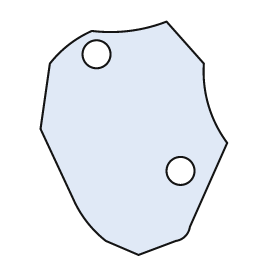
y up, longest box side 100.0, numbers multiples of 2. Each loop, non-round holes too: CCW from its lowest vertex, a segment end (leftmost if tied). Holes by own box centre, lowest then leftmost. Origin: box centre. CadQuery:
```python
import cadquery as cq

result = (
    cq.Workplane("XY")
    .moveTo(2.0, -50.0)
    .lineTo(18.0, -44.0)
    .threePointArc((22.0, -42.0), (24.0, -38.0))
    .lineTo(40.0, -2.0)
    .threePointArc((32.0, 14.0), (30.0, 32.0))
    .lineTo(14.0, 50.0)
    .threePointArc((-2.0, 46.0), (-18.0, 46.0))
    .threePointArc((-28.0, 40.0), (-36.0, 32.0))
    .lineTo(-40.0, 4.0)
    .lineTo(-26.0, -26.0)
    .threePointArc((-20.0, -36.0), (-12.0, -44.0))
    .close()
    .moveTo(20.0, -14.0)
    .circle(6.0)
    .moveTo(-16.0, 36.0)
    .circle(6.0)
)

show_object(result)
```